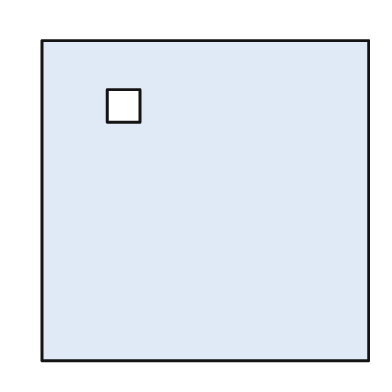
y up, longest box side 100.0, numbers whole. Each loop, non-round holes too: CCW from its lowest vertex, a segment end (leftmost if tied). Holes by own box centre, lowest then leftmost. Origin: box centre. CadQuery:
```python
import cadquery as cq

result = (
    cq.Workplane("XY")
    .moveTo(-50.0, -49.0)
    .lineTo(50.0, -49.0)
    .lineTo(50.0, 49.0)
    .lineTo(-50.0, 49.0)
    .close()
    .moveTo(-30.0, 24.0)
    .lineTo(-20.0, 24.0)
    .lineTo(-20.0, 34.0)
    .lineTo(-30.0, 34.0)
    .close()
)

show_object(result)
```